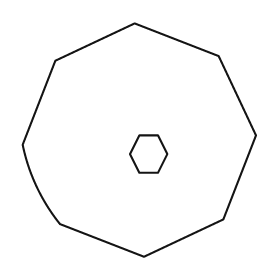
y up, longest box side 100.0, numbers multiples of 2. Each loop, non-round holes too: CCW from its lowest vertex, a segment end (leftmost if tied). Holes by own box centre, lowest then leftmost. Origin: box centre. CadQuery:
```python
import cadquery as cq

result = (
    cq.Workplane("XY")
    .moveTo(2.0, -50.0)
    .lineTo(36.0, -34.0)
    .lineTo(50.0, 2.0)
    .lineTo(34.0, 36.0)
    .lineTo(-2.0, 50.0)
    .lineTo(-36.0, 34.0)
    .lineTo(-50.0, -2.0)
    .threePointArc((-44.0, -20.0), (-34.0, -36.0))
    .close()
    .moveTo(0.0, -14.0)
    .lineTo(8.0, -14.0)
    .lineTo(12.0, -6.0)
    .lineTo(8.0, 2.0)
    .lineTo(0.0, 2.0)
    .lineTo(-4.0, -6.0)
    .close()
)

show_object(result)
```